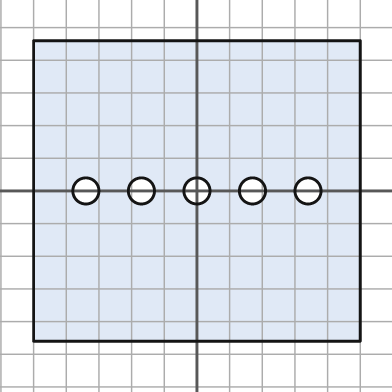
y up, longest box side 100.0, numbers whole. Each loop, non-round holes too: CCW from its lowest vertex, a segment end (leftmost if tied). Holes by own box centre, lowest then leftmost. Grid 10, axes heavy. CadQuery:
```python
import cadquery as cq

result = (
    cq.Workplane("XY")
    .moveTo(-50.0, -46.0)
    .lineTo(50.0, -46.0)
    .lineTo(50.0, 46.0)
    .lineTo(-50.0, 46.0)
    .close()
    .moveTo(-34.0, 0.0)
    .circle(4.0)
    .moveTo(-17.0, 0.0)
    .circle(4.0)
    .moveTo(0.0, 0.0)
    .circle(4.0)
    .moveTo(17.0, 0.0)
    .circle(4.0)
    .moveTo(34.0, 0.0)
    .circle(4.0)
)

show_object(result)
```